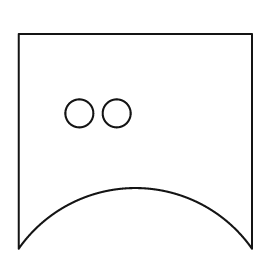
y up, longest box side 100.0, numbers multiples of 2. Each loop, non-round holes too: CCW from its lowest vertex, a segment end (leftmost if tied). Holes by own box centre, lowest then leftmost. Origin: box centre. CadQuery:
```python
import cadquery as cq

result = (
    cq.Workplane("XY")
    .moveTo(-50.0, -46.0)
    .threePointArc((0.0, -20.0), (50.0, -46.0))
    .lineTo(50.0, 46.0)
    .lineTo(-50.0, 46.0)
    .close()
    .moveTo(-24.0, 12.0)
    .circle(6.0)
    .moveTo(-8.0, 12.0)
    .circle(6.0)
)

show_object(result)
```